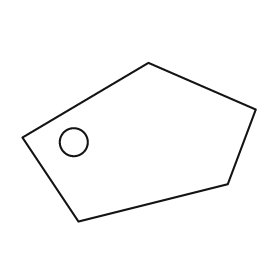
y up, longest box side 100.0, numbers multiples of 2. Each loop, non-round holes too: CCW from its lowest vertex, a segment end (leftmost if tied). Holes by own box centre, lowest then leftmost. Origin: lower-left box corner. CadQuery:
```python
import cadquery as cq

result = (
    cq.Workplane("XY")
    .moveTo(24.0, 0.0)
    .lineTo(88.0, 16.0)
    .lineTo(100.0, 48.0)
    .lineTo(54.0, 68.0)
    .lineTo(0.0, 36.0)
    .close()
    .moveTo(22.0, 34.0)
    .circle(6.0)
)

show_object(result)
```